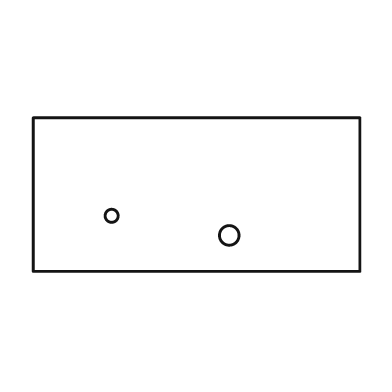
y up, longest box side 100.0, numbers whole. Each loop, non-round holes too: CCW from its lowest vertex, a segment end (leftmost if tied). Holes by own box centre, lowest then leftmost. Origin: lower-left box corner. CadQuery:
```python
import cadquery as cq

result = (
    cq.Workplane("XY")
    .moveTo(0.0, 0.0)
    .lineTo(100.0, 0.0)
    .lineTo(100.0, 47.0)
    .lineTo(0.0, 47.0)
    .close()
    .moveTo(60.0, 11.0)
    .circle(3.0)
    .moveTo(24.0, 17.0)
    .circle(2.0)
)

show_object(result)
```